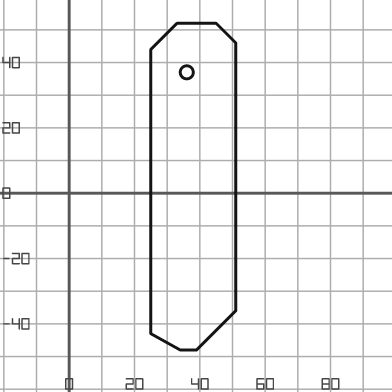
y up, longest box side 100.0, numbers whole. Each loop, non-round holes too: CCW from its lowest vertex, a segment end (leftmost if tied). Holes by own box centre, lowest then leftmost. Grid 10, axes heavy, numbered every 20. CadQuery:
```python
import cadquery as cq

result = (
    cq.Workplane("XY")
    .moveTo(34.0, -48.0)
    .lineTo(39.0, -48.0)
    .lineTo(51.0, -36.0)
    .lineTo(51.0, 46.0)
    .lineTo(45.0, 52.0)
    .lineTo(33.0, 52.0)
    .lineTo(25.0, 44.0)
    .lineTo(25.0, -43.0)
    .close()
    .moveTo(36.0, 37.0)
    .circle(2.0)
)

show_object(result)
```